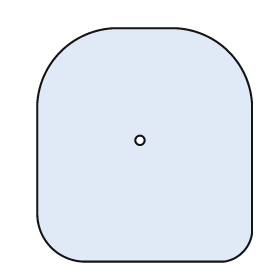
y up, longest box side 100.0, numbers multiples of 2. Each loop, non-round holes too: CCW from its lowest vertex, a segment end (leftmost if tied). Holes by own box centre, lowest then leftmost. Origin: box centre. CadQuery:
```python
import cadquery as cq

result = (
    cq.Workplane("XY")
    .moveTo(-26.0, -50.0)
    .lineTo(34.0, -50.0)
    .threePointArc((42.0, -46.0), (46.0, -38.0))
    .lineTo(46.0, 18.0)
    .threePointArc((36.0, 40.0), (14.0, 50.0))
    .lineTo(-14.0, 50.0)
    .threePointArc((-36.0, 40.0), (-46.0, 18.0))
    .lineTo(-46.0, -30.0)
    .threePointArc((-40.0, -44.0), (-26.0, -50.0))
    .close()
    .moveTo(-2.0, 2.0)
    .circle(2.0)
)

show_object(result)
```